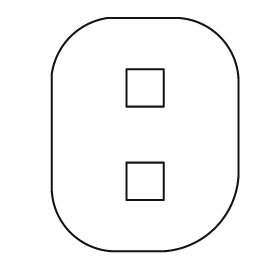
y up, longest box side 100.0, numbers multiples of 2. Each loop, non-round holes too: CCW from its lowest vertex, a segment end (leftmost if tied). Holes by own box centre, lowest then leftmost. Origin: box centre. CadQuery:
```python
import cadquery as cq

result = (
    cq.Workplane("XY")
    .moveTo(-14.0, -50.0)
    .lineTo(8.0, -50.0)
    .threePointArc((30.0, -40.0), (40.0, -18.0))
    .lineTo(40.0, 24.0)
    .threePointArc((32.0, 42.0), (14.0, 50.0))
    .lineTo(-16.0, 50.0)
    .threePointArc((-32.0, 42.0), (-40.0, 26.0))
    .lineTo(-40.0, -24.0)
    .threePointArc((-32.0, -42.0), (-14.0, -50.0))
    .close()
    .moveTo(-8.0, -28.0)
    .lineTo(8.0, -28.0)
    .lineTo(8.0, -12.0)
    .lineTo(-8.0, -12.0)
    .close()
    .moveTo(-8.0, 12.0)
    .lineTo(8.0, 12.0)
    .lineTo(8.0, 28.0)
    .lineTo(-8.0, 28.0)
    .close()
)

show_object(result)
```